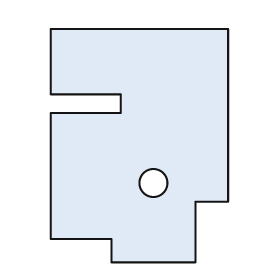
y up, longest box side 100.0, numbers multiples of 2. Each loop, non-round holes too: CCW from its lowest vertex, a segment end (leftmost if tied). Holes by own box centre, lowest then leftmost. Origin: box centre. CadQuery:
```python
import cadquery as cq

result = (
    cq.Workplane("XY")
    .moveTo(-12.0, -50.0)
    .lineTo(24.0, -50.0)
    .lineTo(24.0, -24.0)
    .lineTo(38.0, -24.0)
    .lineTo(38.0, 50.0)
    .lineTo(-38.0, 50.0)
    .lineTo(-38.0, 22.0)
    .lineTo(-8.0, 22.0)
    .lineTo(-8.0, 14.0)
    .lineTo(-38.0, 14.0)
    .lineTo(-38.0, -40.0)
    .lineTo(-12.0, -40.0)
    .close()
    .moveTo(6.0, -16.0)
    .circle(6.0)
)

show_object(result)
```